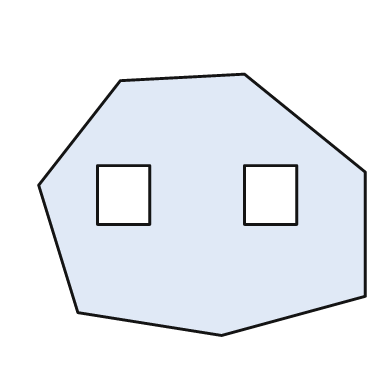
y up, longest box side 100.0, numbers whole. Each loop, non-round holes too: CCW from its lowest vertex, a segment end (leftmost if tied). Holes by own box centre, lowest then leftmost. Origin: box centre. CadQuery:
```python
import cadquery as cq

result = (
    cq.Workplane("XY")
    .moveTo(6.0, -40.0)
    .lineTo(50.0, -28.0)
    .lineTo(50.0, 10.0)
    .lineTo(13.0, 40.0)
    .lineTo(-25.0, 38.0)
    .lineTo(-50.0, 6.0)
    .lineTo(-38.0, -33.0)
    .close()
    .moveTo(-32.0, -6.0)
    .lineTo(-16.0, -6.0)
    .lineTo(-16.0, 12.0)
    .lineTo(-32.0, 12.0)
    .close()
    .moveTo(13.0, -6.0)
    .lineTo(29.0, -6.0)
    .lineTo(29.0, 12.0)
    .lineTo(13.0, 12.0)
    .close()
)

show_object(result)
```